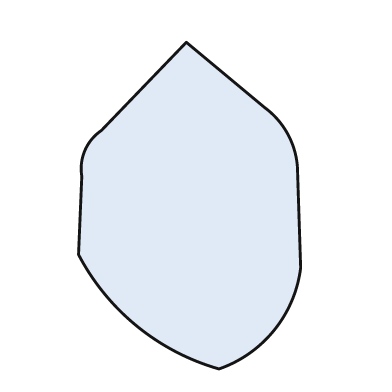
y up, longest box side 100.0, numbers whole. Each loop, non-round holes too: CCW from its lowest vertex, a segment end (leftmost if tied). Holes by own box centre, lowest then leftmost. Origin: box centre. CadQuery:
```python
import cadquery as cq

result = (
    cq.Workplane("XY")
    .moveTo(9.0, -50.0)
    .threePointArc((26.0, -38.0), (34.0, -19.0))
    .lineTo(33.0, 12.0)
    .threePointArc((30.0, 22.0), (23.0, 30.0))
    .lineTo(-1.0, 50.0)
    .lineTo(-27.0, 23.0)
    .threePointArc((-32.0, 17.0), (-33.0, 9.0))
    .lineTo(-34.0, -15.0)
    .threePointArc((-16.0, -37.0), (9.0, -50.0))
    .close()
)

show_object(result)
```